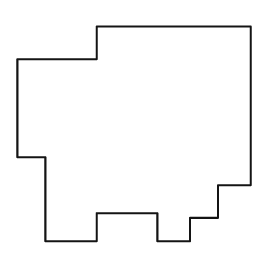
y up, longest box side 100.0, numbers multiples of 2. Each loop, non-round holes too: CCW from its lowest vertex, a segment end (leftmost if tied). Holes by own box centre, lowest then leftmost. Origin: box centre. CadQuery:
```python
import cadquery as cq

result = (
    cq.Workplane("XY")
    .moveTo(-38.0, -46.0)
    .lineTo(-16.0, -46.0)
    .lineTo(-16.0, -34.0)
    .lineTo(10.0, -34.0)
    .lineTo(10.0, -46.0)
    .lineTo(24.0, -46.0)
    .lineTo(24.0, -36.0)
    .lineTo(36.0, -36.0)
    .lineTo(36.0, -22.0)
    .lineTo(50.0, -22.0)
    .lineTo(50.0, 46.0)
    .lineTo(-16.0, 46.0)
    .lineTo(-16.0, 32.0)
    .lineTo(-50.0, 32.0)
    .lineTo(-50.0, -10.0)
    .lineTo(-38.0, -10.0)
    .close()
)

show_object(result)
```